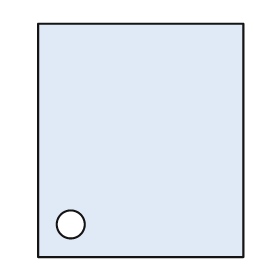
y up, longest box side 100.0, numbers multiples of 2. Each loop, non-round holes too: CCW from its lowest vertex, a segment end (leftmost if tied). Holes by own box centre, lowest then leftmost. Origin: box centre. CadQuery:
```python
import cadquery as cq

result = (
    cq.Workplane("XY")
    .moveTo(-44.0, -50.0)
    .lineTo(44.0, -50.0)
    .lineTo(44.0, 50.0)
    .lineTo(-44.0, 50.0)
    .close()
    .moveTo(-30.0, -36.0)
    .circle(6.0)
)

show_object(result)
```